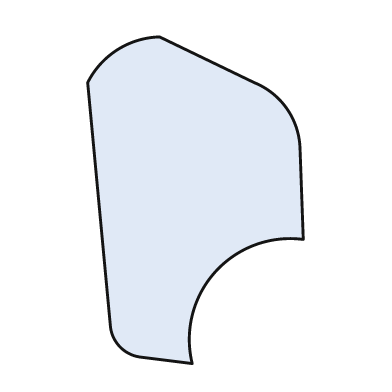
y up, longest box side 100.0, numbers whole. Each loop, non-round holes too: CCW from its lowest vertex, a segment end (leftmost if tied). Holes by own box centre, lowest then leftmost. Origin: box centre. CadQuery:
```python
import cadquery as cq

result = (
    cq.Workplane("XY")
    .moveTo(-1.0, -50.0)
    .threePointArc((6.0, -22.0), (33.0, -12.0))
    .lineTo(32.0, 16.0)
    .threePointArc((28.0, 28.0), (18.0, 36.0))
    .lineTo(-11.0, 50.0)
    .threePointArc((-24.0, 46.0), (-33.0, 36.0))
    .lineTo(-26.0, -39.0)
    .threePointArc((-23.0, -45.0), (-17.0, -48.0))
    .close()
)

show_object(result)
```